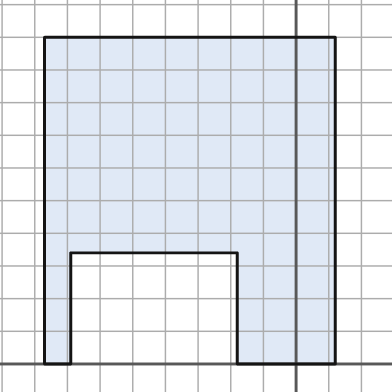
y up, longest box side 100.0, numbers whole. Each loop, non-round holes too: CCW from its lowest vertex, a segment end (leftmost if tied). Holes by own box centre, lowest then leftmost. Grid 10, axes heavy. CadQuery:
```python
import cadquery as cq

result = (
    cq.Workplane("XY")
    .moveTo(-77.0, 0.0)
    .lineTo(-69.0, 0.0)
    .lineTo(-69.0, 34.0)
    .lineTo(-18.0, 34.0)
    .lineTo(-18.0, 0.0)
    .lineTo(12.0, 0.0)
    .lineTo(12.0, 100.0)
    .lineTo(-77.0, 100.0)
    .close()
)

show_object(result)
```